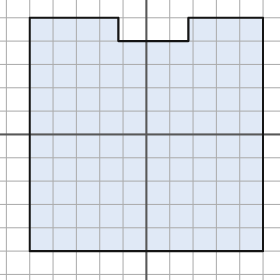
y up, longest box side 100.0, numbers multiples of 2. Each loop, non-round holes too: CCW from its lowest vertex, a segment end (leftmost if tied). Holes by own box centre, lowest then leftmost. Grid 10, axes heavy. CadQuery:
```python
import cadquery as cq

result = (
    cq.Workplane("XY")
    .moveTo(-50.0, -50.0)
    .lineTo(50.0, -50.0)
    .lineTo(50.0, 50.0)
    .lineTo(18.0, 50.0)
    .lineTo(18.0, 40.0)
    .lineTo(-12.0, 40.0)
    .lineTo(-12.0, 50.0)
    .lineTo(-50.0, 50.0)
    .close()
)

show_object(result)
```